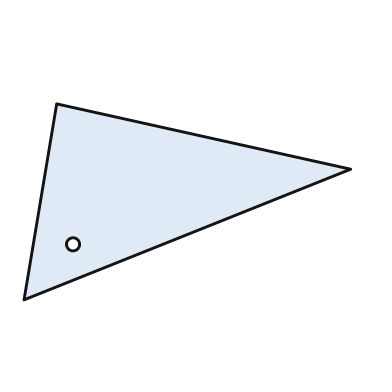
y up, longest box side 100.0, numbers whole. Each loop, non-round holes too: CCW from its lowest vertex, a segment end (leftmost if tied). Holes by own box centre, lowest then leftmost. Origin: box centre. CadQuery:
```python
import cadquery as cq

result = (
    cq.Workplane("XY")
    .moveTo(-50.0, -30.0)
    .lineTo(50.0, 10.0)
    .lineTo(-40.0, 30.0)
    .close()
    .moveTo(-35.0, -13.0)
    .circle(2.0)
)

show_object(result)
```